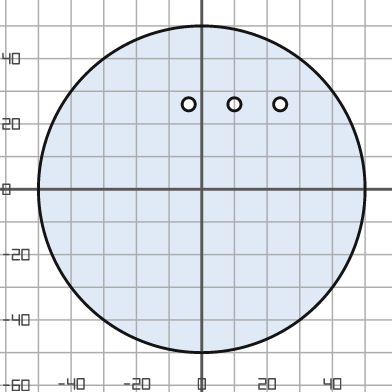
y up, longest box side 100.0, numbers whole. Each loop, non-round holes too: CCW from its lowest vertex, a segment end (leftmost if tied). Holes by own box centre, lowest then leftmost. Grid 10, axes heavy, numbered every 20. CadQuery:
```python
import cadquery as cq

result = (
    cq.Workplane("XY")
    .moveTo(0.0, 0.0)
    .circle(50.0)
    .moveTo(-4.0, 26.0)
    .circle(2.0)
    .moveTo(10.0, 26.0)
    .circle(2.0)
    .moveTo(24.0, 26.0)
    .circle(2.0)
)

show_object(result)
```